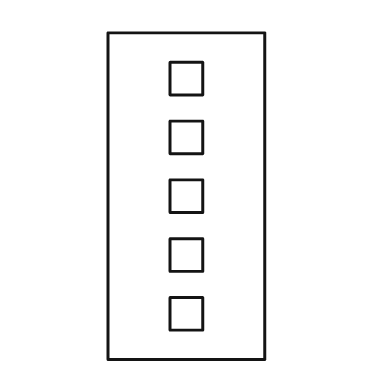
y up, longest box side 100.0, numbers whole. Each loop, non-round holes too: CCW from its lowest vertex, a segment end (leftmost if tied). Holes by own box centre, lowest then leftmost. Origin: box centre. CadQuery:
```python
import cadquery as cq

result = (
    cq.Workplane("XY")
    .moveTo(-24.0, -50.0)
    .lineTo(24.0, -50.0)
    .lineTo(24.0, 50.0)
    .lineTo(-24.0, 50.0)
    .close()
    .moveTo(-5.0, -41.0)
    .lineTo(5.0, -41.0)
    .lineTo(5.0, -31.0)
    .lineTo(-5.0, -31.0)
    .close()
    .moveTo(-5.0, -23.0)
    .lineTo(5.0, -23.0)
    .lineTo(5.0, -13.0)
    .lineTo(-5.0, -13.0)
    .close()
    .moveTo(-5.0, -5.0)
    .lineTo(5.0, -5.0)
    .lineTo(5.0, 5.0)
    .lineTo(-5.0, 5.0)
    .close()
    .moveTo(-5.0, 13.0)
    .lineTo(5.0, 13.0)
    .lineTo(5.0, 23.0)
    .lineTo(-5.0, 23.0)
    .close()
    .moveTo(-5.0, 31.0)
    .lineTo(5.0, 31.0)
    .lineTo(5.0, 41.0)
    .lineTo(-5.0, 41.0)
    .close()
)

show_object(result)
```